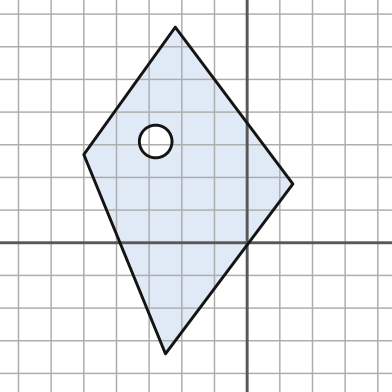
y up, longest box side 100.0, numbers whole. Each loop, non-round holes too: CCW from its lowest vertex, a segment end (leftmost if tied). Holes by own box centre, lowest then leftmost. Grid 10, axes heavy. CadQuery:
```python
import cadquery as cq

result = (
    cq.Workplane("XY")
    .moveTo(-25.0, -34.0)
    .lineTo(14.0, 18.0)
    .lineTo(-22.0, 66.0)
    .lineTo(-50.0, 27.0)
    .close()
    .moveTo(-28.0, 31.0)
    .circle(5.0)
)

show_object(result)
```